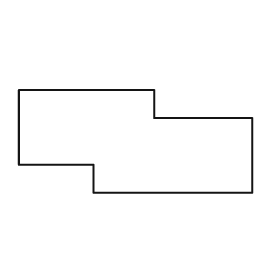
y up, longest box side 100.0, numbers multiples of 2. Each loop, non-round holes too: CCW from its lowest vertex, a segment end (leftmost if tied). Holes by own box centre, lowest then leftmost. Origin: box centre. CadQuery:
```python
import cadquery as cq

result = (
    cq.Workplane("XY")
    .moveTo(-18.0, -22.0)
    .lineTo(50.0, -22.0)
    .lineTo(50.0, 10.0)
    .lineTo(8.0, 10.0)
    .lineTo(8.0, 22.0)
    .lineTo(-50.0, 22.0)
    .lineTo(-50.0, -10.0)
    .lineTo(-18.0, -10.0)
    .close()
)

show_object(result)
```